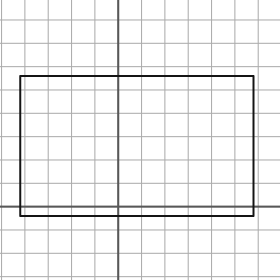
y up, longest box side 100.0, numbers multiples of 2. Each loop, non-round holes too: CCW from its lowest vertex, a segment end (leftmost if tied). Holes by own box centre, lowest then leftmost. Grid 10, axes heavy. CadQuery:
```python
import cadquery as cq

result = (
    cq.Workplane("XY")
    .moveTo(-42.0, -4.0)
    .lineTo(58.0, -4.0)
    .lineTo(58.0, 56.0)
    .lineTo(-42.0, 56.0)
    .close()
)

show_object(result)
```